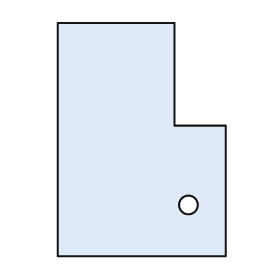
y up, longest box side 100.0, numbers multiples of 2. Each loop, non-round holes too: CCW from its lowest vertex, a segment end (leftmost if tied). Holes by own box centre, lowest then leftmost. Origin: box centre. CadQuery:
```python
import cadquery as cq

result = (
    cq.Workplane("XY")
    .moveTo(-36.0, -50.0)
    .lineTo(36.0, -50.0)
    .lineTo(36.0, 6.0)
    .lineTo(14.0, 6.0)
    .lineTo(14.0, 50.0)
    .lineTo(-36.0, 50.0)
    .close()
    .moveTo(20.0, -28.0)
    .circle(4.0)
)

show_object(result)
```